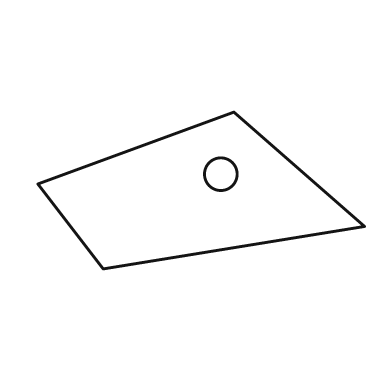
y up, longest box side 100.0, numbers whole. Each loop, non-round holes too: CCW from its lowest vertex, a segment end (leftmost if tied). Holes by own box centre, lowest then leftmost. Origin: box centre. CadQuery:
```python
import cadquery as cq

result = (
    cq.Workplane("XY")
    .moveTo(-30.0, -24.0)
    .lineTo(50.0, -11.0)
    .lineTo(10.0, 24.0)
    .lineTo(-50.0, 2.0)
    .close()
    .moveTo(6.0, 5.0)
    .circle(5.0)
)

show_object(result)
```